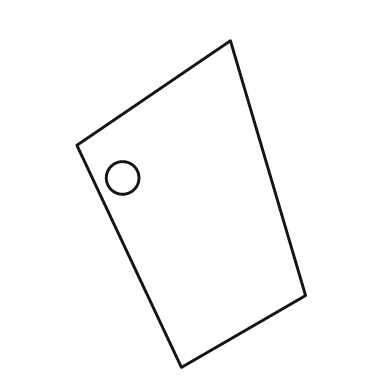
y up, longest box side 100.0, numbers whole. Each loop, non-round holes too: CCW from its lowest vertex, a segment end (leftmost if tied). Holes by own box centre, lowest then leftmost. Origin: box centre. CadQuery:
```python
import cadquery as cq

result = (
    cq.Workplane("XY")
    .moveTo(-3.0, -50.0)
    .lineTo(35.0, -28.0)
    .lineTo(12.0, 50.0)
    .lineTo(-35.0, 18.0)
    .close()
    .moveTo(-21.0, 8.0)
    .circle(5.0)
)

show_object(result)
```